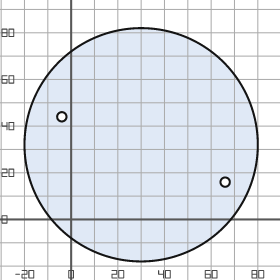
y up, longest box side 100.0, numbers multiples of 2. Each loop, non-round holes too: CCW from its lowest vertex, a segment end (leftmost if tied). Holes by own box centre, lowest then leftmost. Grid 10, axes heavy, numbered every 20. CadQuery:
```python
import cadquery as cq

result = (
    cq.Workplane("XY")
    .moveTo(30.0, 32.0)
    .circle(50.0)
    .moveTo(66.0, 16.0)
    .circle(2.0)
    .moveTo(-4.0, 44.0)
    .circle(2.0)
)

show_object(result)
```